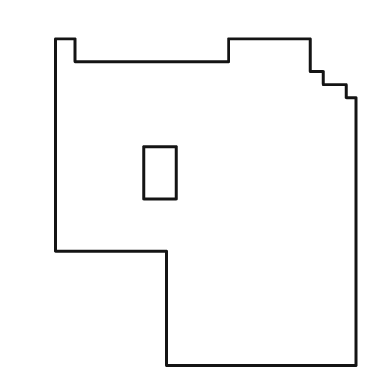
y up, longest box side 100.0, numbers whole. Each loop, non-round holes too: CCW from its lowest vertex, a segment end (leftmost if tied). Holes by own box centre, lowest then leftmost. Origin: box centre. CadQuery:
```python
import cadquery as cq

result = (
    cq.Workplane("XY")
    .moveTo(-12.0, -50.0)
    .lineTo(46.0, -50.0)
    .lineTo(46.0, 32.0)
    .lineTo(43.0, 32.0)
    .lineTo(43.0, 36.0)
    .lineTo(36.0, 36.0)
    .lineTo(36.0, 40.0)
    .lineTo(32.0, 40.0)
    .lineTo(32.0, 50.0)
    .lineTo(7.0, 50.0)
    .lineTo(7.0, 43.0)
    .lineTo(-40.0, 43.0)
    .lineTo(-40.0, 50.0)
    .lineTo(-46.0, 50.0)
    .lineTo(-46.0, -15.0)
    .lineTo(-12.0, -15.0)
    .close()
    .moveTo(-19.0, 1.0)
    .lineTo(-9.0, 1.0)
    .lineTo(-9.0, 17.0)
    .lineTo(-19.0, 17.0)
    .close()
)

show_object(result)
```